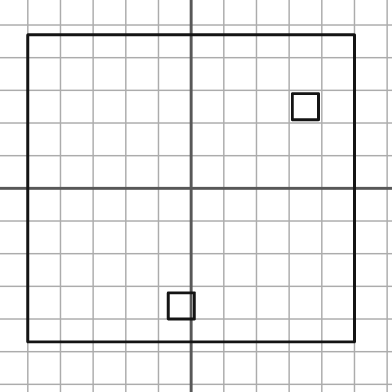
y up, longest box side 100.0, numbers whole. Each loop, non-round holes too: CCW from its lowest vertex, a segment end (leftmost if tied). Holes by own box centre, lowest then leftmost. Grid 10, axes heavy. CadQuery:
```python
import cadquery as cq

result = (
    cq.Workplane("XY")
    .moveTo(-50.0, -47.0)
    .lineTo(50.0, -47.0)
    .lineTo(50.0, 47.0)
    .lineTo(-50.0, 47.0)
    .close()
    .moveTo(-7.0, -40.0)
    .lineTo(1.0, -40.0)
    .lineTo(1.0, -32.0)
    .lineTo(-7.0, -32.0)
    .close()
    .moveTo(31.0, 21.0)
    .lineTo(39.0, 21.0)
    .lineTo(39.0, 29.0)
    .lineTo(31.0, 29.0)
    .close()
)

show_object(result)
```